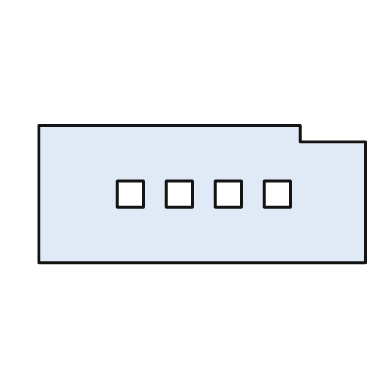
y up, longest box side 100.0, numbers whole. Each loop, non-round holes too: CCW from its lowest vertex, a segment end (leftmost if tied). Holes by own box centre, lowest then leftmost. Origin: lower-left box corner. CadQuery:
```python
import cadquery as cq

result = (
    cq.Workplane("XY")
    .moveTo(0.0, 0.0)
    .lineTo(100.0, 0.0)
    .lineTo(100.0, 37.0)
    .lineTo(80.0, 37.0)
    .lineTo(80.0, 42.0)
    .lineTo(0.0, 42.0)
    .close()
    .moveTo(24.0, 17.0)
    .lineTo(32.0, 17.0)
    .lineTo(32.0, 25.0)
    .lineTo(24.0, 25.0)
    .close()
    .moveTo(39.0, 17.0)
    .lineTo(47.0, 17.0)
    .lineTo(47.0, 25.0)
    .lineTo(39.0, 25.0)
    .close()
    .moveTo(54.0, 17.0)
    .lineTo(62.0, 17.0)
    .lineTo(62.0, 25.0)
    .lineTo(54.0, 25.0)
    .close()
    .moveTo(69.0, 17.0)
    .lineTo(77.0, 17.0)
    .lineTo(77.0, 25.0)
    .lineTo(69.0, 25.0)
    .close()
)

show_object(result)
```